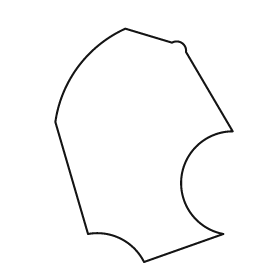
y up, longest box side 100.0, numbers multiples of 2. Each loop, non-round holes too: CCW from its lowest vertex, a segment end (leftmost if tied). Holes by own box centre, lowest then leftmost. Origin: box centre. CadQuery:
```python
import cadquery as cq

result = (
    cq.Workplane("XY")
    .moveTo(0.0, -50.0)
    .lineTo(34.0, -38.0)
    .threePointArc((16.0, -14.0), (38.0, 6.0))
    .lineTo(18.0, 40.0)
    .threePointArc((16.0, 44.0), (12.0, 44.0))
    .lineTo(-8.0, 50.0)
    .threePointArc((-28.0, 34.0), (-38.0, 10.0))
    .lineTo(-24.0, -38.0)
    .threePointArc((-10.0, -40.0), (0.0, -50.0))
    .close()
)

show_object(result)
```